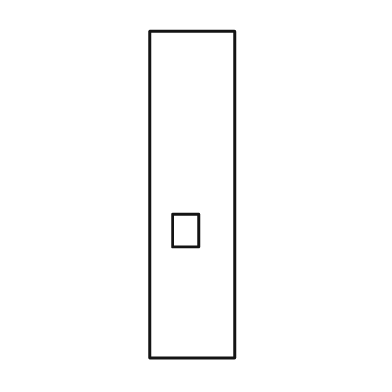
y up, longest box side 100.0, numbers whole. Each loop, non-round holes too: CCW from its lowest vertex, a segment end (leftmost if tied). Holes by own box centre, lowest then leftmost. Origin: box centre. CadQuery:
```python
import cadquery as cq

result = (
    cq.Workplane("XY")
    .moveTo(-13.0, -50.0)
    .lineTo(13.0, -50.0)
    .lineTo(13.0, 50.0)
    .lineTo(-13.0, 50.0)
    .close()
    .moveTo(-6.0, -16.0)
    .lineTo(2.0, -16.0)
    .lineTo(2.0, -6.0)
    .lineTo(-6.0, -6.0)
    .close()
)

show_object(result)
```